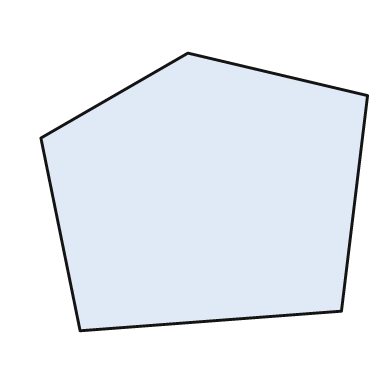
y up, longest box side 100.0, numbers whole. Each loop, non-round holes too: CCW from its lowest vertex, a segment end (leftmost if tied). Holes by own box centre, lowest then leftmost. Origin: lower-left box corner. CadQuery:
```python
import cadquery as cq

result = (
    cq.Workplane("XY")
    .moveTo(12.0, 0.0)
    .lineTo(92.0, 6.0)
    .lineTo(100.0, 72.0)
    .lineTo(45.0, 85.0)
    .lineTo(0.0, 59.0)
    .close()
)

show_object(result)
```